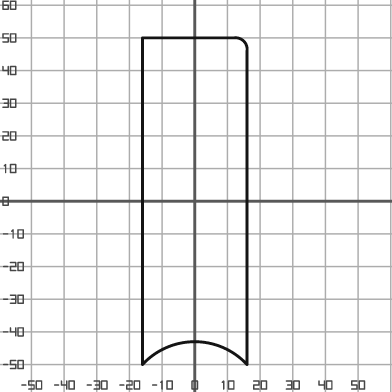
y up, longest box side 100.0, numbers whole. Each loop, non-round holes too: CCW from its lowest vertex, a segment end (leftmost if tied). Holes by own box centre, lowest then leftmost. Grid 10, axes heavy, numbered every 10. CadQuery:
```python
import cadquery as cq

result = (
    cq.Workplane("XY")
    .moveTo(-16.0, -50.0)
    .threePointArc((0.0, -43.0), (16.0, -50.0))
    .lineTo(16.0, 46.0)
    .threePointArc((15.0, 49.0), (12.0, 50.0))
    .lineTo(-16.0, 50.0)
    .close()
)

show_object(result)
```